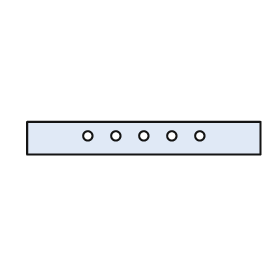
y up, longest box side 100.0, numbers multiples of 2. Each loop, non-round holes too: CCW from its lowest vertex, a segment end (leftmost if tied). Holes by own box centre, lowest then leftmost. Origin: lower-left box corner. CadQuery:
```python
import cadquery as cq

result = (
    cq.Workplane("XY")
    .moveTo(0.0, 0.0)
    .lineTo(100.0, 0.0)
    .lineTo(100.0, 14.0)
    .lineTo(0.0, 14.0)
    .close()
    .moveTo(26.0, 8.0)
    .circle(2.0)
    .moveTo(38.0, 8.0)
    .circle(2.0)
    .moveTo(50.0, 8.0)
    .circle(2.0)
    .moveTo(62.0, 8.0)
    .circle(2.0)
    .moveTo(74.0, 8.0)
    .circle(2.0)
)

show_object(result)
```